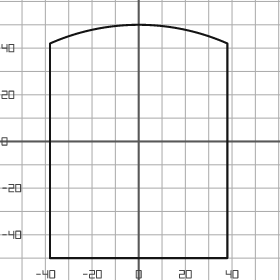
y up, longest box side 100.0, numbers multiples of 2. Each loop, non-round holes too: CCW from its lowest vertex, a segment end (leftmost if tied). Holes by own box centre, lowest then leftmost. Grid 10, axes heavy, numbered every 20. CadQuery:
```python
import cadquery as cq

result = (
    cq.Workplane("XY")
    .moveTo(-38.0, -50.0)
    .lineTo(38.0, -50.0)
    .lineTo(38.0, 42.0)
    .threePointArc((0.0, 50.0), (-38.0, 42.0))
    .close()
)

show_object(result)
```